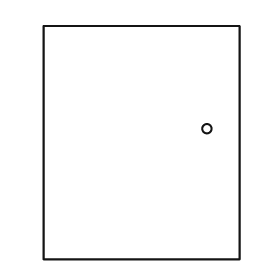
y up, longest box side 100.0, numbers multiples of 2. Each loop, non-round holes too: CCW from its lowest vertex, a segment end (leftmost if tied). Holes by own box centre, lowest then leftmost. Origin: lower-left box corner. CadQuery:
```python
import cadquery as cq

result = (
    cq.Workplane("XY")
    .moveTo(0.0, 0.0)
    .lineTo(84.0, 0.0)
    .lineTo(84.0, 100.0)
    .lineTo(0.0, 100.0)
    .close()
    .moveTo(70.0, 56.0)
    .circle(2.0)
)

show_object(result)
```